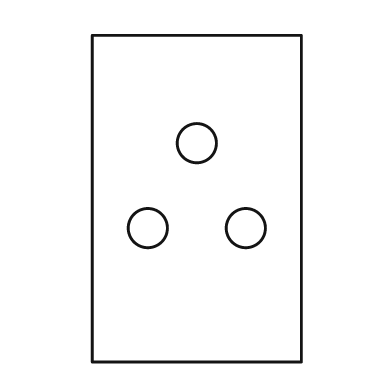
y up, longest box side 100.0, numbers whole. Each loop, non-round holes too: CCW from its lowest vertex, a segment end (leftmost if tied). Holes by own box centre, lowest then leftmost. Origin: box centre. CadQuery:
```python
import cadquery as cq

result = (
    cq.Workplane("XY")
    .moveTo(-32.0, -50.0)
    .lineTo(32.0, -50.0)
    .lineTo(32.0, 50.0)
    .lineTo(-32.0, 50.0)
    .close()
    .moveTo(-15.0, -9.0)
    .circle(6.0)
    .moveTo(15.0, -9.0)
    .circle(6.0)
    .moveTo(0.0, 17.0)
    .circle(6.0)
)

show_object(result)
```